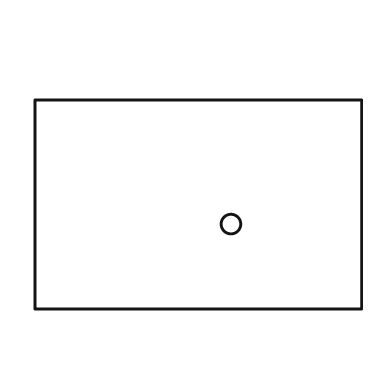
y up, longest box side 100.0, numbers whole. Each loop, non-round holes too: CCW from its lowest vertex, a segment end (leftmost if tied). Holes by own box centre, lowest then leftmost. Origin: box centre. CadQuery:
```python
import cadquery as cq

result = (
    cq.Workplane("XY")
    .moveTo(-50.0, -32.0)
    .lineTo(50.0, -32.0)
    .lineTo(50.0, 32.0)
    .lineTo(-50.0, 32.0)
    .close()
    .moveTo(10.0, -6.0)
    .circle(3.0)
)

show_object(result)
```